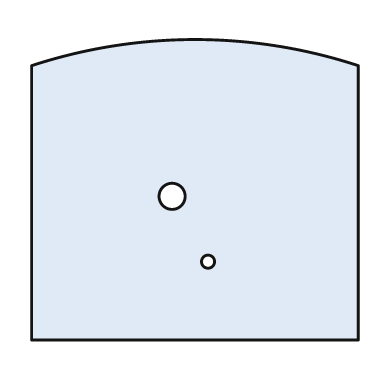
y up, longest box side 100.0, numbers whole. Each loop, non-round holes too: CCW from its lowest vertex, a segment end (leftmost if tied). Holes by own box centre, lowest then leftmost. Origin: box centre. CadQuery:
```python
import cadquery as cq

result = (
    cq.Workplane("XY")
    .moveTo(-50.0, -46.0)
    .lineTo(50.0, -46.0)
    .lineTo(50.0, 38.0)
    .threePointArc((0.0, 46.0), (-50.0, 38.0))
    .close()
    .moveTo(4.0, -22.0)
    .circle(2.0)
    .moveTo(-7.0, -2.0)
    .circle(4.0)
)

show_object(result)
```